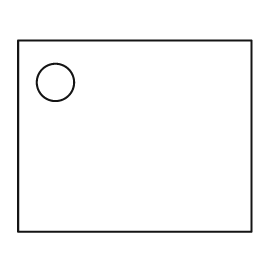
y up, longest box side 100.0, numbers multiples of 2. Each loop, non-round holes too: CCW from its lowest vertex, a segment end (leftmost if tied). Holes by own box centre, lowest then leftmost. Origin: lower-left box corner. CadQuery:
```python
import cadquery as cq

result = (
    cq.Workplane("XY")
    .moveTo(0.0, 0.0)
    .lineTo(100.0, 0.0)
    .lineTo(100.0, 82.0)
    .lineTo(0.0, 82.0)
    .close()
    .moveTo(16.0, 64.0)
    .circle(8.0)
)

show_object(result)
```